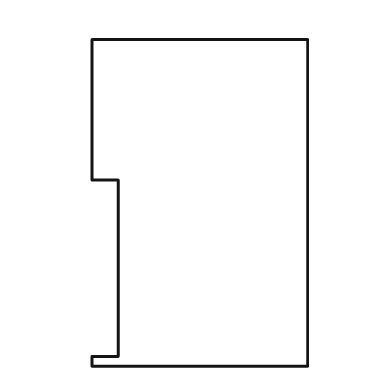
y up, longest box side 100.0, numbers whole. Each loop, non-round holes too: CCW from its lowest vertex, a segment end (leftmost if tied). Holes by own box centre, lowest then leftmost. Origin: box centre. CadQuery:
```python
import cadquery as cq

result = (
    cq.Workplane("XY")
    .moveTo(-33.0, -50.0)
    .lineTo(33.0, -50.0)
    .lineTo(33.0, 50.0)
    .lineTo(-33.0, 50.0)
    .lineTo(-33.0, 7.0)
    .lineTo(-25.0, 7.0)
    .lineTo(-25.0, -47.0)
    .lineTo(-33.0, -47.0)
    .close()
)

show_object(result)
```